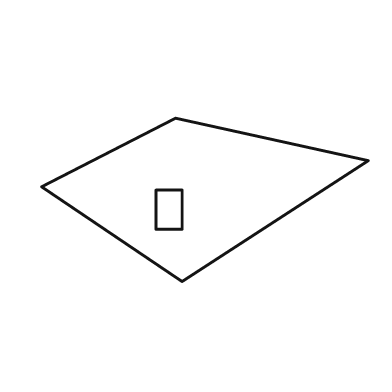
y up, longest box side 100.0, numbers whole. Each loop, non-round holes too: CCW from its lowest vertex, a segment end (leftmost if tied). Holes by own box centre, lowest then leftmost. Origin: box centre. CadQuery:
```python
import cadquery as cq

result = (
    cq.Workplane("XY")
    .moveTo(-7.0, -25.0)
    .lineTo(50.0, 12.0)
    .lineTo(-9.0, 25.0)
    .lineTo(-50.0, 4.0)
    .close()
    .moveTo(-15.0, -9.0)
    .lineTo(-7.0, -9.0)
    .lineTo(-7.0, 3.0)
    .lineTo(-15.0, 3.0)
    .close()
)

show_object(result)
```